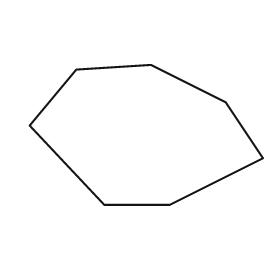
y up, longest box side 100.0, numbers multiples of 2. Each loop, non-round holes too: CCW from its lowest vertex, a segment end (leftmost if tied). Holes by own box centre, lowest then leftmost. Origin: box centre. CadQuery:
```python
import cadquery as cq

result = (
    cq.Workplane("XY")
    .moveTo(-18.0, -30.0)
    .lineTo(10.0, -30.0)
    .lineTo(50.0, -10.0)
    .lineTo(34.0, 14.0)
    .lineTo(2.0, 30.0)
    .lineTo(-30.0, 28.0)
    .lineTo(-50.0, 4.0)
    .close()
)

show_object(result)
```